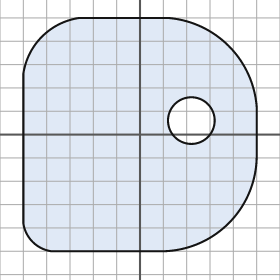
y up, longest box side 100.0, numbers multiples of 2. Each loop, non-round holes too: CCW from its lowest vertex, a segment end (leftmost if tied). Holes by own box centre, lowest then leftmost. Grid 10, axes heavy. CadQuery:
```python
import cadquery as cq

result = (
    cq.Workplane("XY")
    .moveTo(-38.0, -50.0)
    .lineTo(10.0, -50.0)
    .threePointArc((38.0, -38.0), (50.0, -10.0))
    .lineTo(50.0, 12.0)
    .threePointArc((38.0, 38.0), (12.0, 50.0))
    .lineTo(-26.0, 50.0)
    .threePointArc((-42.0, 42.0), (-50.0, 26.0))
    .lineTo(-50.0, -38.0)
    .threePointArc((-46.0, -46.0), (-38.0, -50.0))
    .close()
    .moveTo(22.0, 6.0)
    .circle(10.0)
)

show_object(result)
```